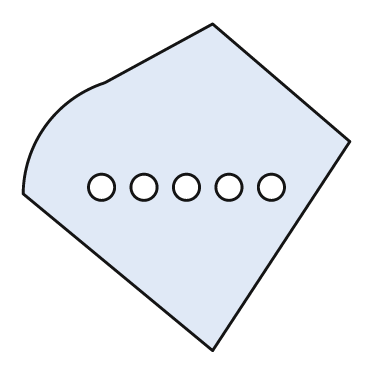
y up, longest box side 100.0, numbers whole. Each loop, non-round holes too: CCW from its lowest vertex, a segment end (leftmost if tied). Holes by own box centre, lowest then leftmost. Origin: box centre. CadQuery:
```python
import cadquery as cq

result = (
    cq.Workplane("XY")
    .moveTo(8.0, -50.0)
    .lineTo(50.0, 14.0)
    .lineTo(8.0, 50.0)
    .lineTo(-25.0, 32.0)
    .threePointArc((-43.0, 19.0), (-50.0, -2.0))
    .close()
    .moveTo(-26.0, 0.0)
    .circle(4.0)
    .moveTo(-13.0, 0.0)
    .circle(4.0)
    .moveTo(0.0, 0.0)
    .circle(4.0)
    .moveTo(13.0, 0.0)
    .circle(4.0)
    .moveTo(26.0, 0.0)
    .circle(4.0)
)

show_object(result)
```